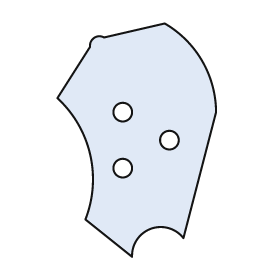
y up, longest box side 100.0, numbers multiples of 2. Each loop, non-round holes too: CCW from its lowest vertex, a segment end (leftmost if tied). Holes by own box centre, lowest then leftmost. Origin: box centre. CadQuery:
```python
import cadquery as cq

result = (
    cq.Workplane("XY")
    .moveTo(-2.0, -50.0)
    .threePointArc((6.0, -38.0), (20.0, -42.0))
    .lineTo(34.0, 12.0)
    .threePointArc((28.0, 34.0), (12.0, 50.0))
    .lineTo(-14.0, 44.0)
    .threePointArc((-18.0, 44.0), (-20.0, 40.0))
    .lineTo(-34.0, 18.0)
    .threePointArc((-20.0, -6.0), (-22.0, -34.0))
    .close()
    .moveTo(-6.0, -12.0)
    .circle(4.0)
    .moveTo(14.0, 0.0)
    .circle(4.0)
    .moveTo(-6.0, 12.0)
    .circle(4.0)
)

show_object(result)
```